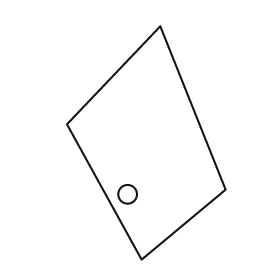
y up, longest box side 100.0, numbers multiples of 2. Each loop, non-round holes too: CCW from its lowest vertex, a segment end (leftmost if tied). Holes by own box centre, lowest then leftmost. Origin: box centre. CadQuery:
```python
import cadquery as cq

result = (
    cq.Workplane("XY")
    .moveTo(-2.0, -50.0)
    .lineTo(34.0, -20.0)
    .lineTo(6.0, 50.0)
    .lineTo(-34.0, 8.0)
    .close()
    .moveTo(-8.0, -22.0)
    .circle(4.0)
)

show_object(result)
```